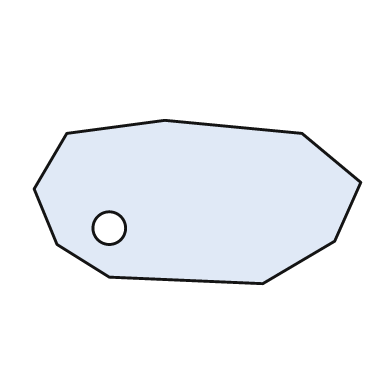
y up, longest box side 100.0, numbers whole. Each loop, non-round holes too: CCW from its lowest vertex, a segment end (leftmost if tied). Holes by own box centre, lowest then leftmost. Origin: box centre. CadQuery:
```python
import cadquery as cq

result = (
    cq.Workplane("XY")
    .moveTo(20.0, -25.0)
    .lineTo(42.0, -12.0)
    .lineTo(50.0, 6.0)
    .lineTo(32.0, 21.0)
    .lineTo(-10.0, 25.0)
    .lineTo(-40.0, 21.0)
    .lineTo(-50.0, 4.0)
    .lineTo(-43.0, -13.0)
    .lineTo(-27.0, -23.0)
    .close()
    .moveTo(-27.0, -8.0)
    .circle(5.0)
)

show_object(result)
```